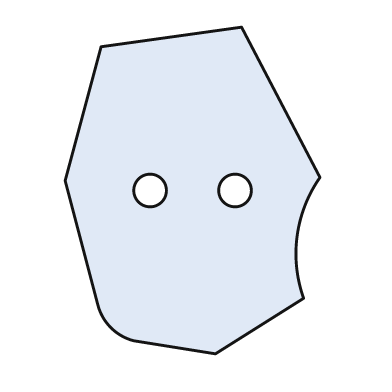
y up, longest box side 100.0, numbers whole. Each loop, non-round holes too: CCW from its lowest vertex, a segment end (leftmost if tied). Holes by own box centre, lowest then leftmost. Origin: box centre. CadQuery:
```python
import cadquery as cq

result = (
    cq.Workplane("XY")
    .moveTo(7.0, -50.0)
    .lineTo(34.0, -33.0)
    .threePointArc((32.0, -14.0), (39.0, 4.0))
    .lineTo(15.0, 50.0)
    .lineTo(-28.0, 44.0)
    .lineTo(-39.0, 3.0)
    .lineTo(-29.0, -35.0)
    .threePointArc((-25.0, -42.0), (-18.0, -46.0))
    .close()
    .moveTo(-13.0, 0.0)
    .circle(5.0)
    .moveTo(13.0, 0.0)
    .circle(5.0)
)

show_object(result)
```